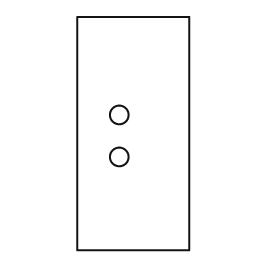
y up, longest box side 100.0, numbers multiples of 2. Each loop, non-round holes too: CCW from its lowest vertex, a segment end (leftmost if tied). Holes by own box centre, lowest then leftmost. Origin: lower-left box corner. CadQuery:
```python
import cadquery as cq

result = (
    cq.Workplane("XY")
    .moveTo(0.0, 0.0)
    .lineTo(48.0, 0.0)
    .lineTo(48.0, 100.0)
    .lineTo(0.0, 100.0)
    .close()
    .moveTo(18.0, 40.0)
    .circle(4.0)
    .moveTo(18.0, 58.0)
    .circle(4.0)
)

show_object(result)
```